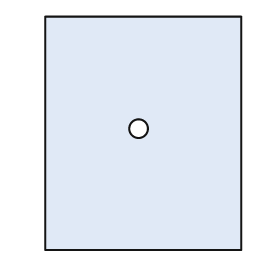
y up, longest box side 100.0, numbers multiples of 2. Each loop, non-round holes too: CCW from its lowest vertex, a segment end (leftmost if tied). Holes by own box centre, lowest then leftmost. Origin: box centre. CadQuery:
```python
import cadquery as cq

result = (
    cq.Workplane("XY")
    .moveTo(-42.0, -50.0)
    .lineTo(42.0, -50.0)
    .lineTo(42.0, 50.0)
    .lineTo(-42.0, 50.0)
    .close()
    .moveTo(-2.0, 2.0)
    .circle(4.0)
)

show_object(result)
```